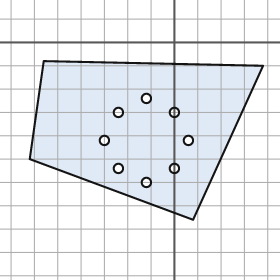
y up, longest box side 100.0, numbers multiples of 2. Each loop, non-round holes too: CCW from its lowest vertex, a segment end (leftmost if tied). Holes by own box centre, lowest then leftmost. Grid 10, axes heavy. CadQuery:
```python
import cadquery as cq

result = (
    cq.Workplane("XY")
    .moveTo(8.0, -76.0)
    .lineTo(38.0, -10.0)
    .lineTo(-56.0, -8.0)
    .lineTo(-62.0, -50.0)
    .close()
    .moveTo(-12.0, -60.0)
    .circle(2.0)
    .moveTo(-24.0, -54.0)
    .circle(2.0)
    .moveTo(0.0, -54.0)
    .circle(2.0)
    .moveTo(-30.0, -42.0)
    .circle(2.0)
    .moveTo(6.0, -42.0)
    .circle(2.0)
    .moveTo(-24.0, -30.0)
    .circle(2.0)
    .moveTo(0.0, -30.0)
    .circle(2.0)
    .moveTo(-12.0, -24.0)
    .circle(2.0)
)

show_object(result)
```